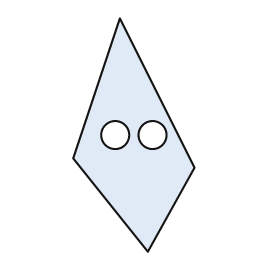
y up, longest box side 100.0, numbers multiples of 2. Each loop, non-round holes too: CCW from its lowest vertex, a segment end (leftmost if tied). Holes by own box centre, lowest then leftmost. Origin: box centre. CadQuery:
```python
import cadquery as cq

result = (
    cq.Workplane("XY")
    .moveTo(6.0, -50.0)
    .lineTo(26.0, -14.0)
    .lineTo(-6.0, 50.0)
    .lineTo(-26.0, -10.0)
    .close()
    .moveTo(-8.0, 0.0)
    .circle(6.0)
    .moveTo(8.0, 0.0)
    .circle(6.0)
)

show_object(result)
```